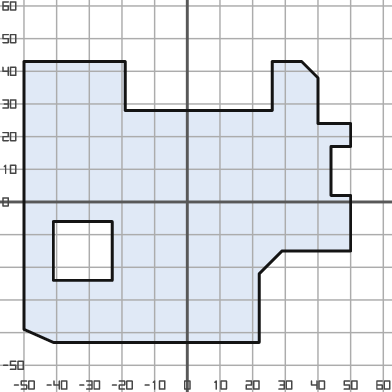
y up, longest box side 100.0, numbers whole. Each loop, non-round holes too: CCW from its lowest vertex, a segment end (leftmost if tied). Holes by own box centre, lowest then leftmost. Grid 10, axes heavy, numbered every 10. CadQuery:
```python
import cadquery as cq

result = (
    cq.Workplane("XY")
    .moveTo(-41.0, -43.0)
    .lineTo(22.0, -43.0)
    .lineTo(22.0, -22.0)
    .lineTo(29.0, -15.0)
    .lineTo(50.0, -15.0)
    .lineTo(50.0, 2.0)
    .lineTo(44.0, 2.0)
    .lineTo(44.0, 17.0)
    .lineTo(50.0, 17.0)
    .lineTo(50.0, 24.0)
    .lineTo(40.0, 24.0)
    .lineTo(40.0, 38.0)
    .lineTo(35.0, 43.0)
    .lineTo(26.0, 43.0)
    .lineTo(26.0, 28.0)
    .lineTo(-19.0, 28.0)
    .lineTo(-19.0, 43.0)
    .lineTo(-50.0, 43.0)
    .lineTo(-50.0, -39.0)
    .close()
    .moveTo(-41.0, -24.0)
    .lineTo(-23.0, -24.0)
    .lineTo(-23.0, -6.0)
    .lineTo(-41.0, -6.0)
    .close()
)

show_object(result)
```